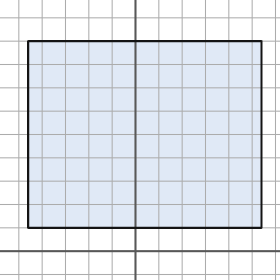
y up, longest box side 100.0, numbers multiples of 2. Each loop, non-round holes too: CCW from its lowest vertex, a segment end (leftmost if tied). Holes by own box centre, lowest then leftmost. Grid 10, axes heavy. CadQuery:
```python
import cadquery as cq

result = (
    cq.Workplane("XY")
    .moveTo(-46.0, 10.0)
    .lineTo(54.0, 10.0)
    .lineTo(54.0, 90.0)
    .lineTo(-46.0, 90.0)
    .close()
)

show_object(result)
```